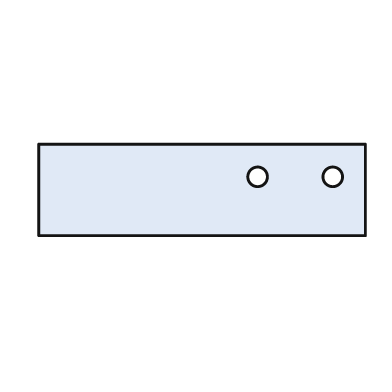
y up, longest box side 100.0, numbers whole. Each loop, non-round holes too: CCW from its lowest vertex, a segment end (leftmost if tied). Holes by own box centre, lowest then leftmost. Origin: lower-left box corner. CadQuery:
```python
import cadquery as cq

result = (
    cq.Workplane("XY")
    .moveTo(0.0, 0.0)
    .lineTo(100.0, 0.0)
    .lineTo(100.0, 28.0)
    .lineTo(0.0, 28.0)
    .close()
    .moveTo(67.0, 18.0)
    .circle(3.0)
    .moveTo(90.0, 18.0)
    .circle(3.0)
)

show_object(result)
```